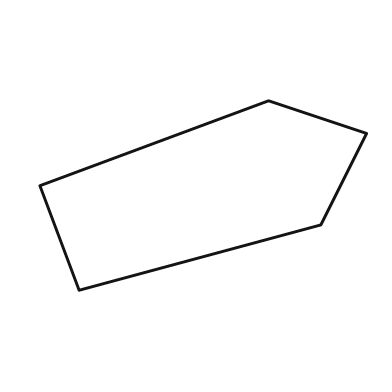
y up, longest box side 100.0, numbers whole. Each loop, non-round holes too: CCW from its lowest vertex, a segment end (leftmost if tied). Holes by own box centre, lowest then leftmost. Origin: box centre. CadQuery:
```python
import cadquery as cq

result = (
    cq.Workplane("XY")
    .moveTo(-38.0, -29.0)
    .lineTo(36.0, -9.0)
    .lineTo(50.0, 19.0)
    .lineTo(20.0, 29.0)
    .lineTo(-50.0, 3.0)
    .close()
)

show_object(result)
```